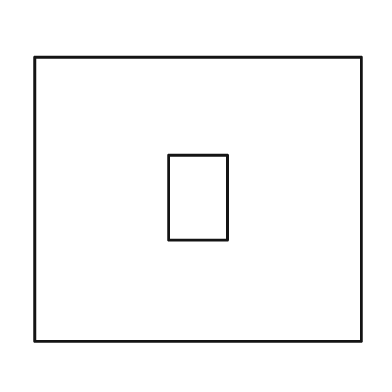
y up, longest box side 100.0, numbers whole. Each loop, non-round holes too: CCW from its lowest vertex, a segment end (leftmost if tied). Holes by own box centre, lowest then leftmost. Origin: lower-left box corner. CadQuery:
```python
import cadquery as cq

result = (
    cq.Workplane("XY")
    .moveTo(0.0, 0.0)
    .lineTo(100.0, 0.0)
    .lineTo(100.0, 87.0)
    .lineTo(0.0, 87.0)
    .close()
    .moveTo(41.0, 31.0)
    .lineTo(59.0, 31.0)
    .lineTo(59.0, 57.0)
    .lineTo(41.0, 57.0)
    .close()
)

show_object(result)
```